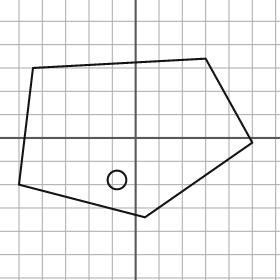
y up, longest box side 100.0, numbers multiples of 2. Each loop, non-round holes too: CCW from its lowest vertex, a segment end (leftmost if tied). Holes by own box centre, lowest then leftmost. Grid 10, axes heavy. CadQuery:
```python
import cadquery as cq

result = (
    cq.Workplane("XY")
    .moveTo(4.0, -34.0)
    .lineTo(50.0, -2.0)
    .lineTo(30.0, 34.0)
    .lineTo(-44.0, 30.0)
    .lineTo(-50.0, -20.0)
    .close()
    .moveTo(-8.0, -18.0)
    .circle(4.0)
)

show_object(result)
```